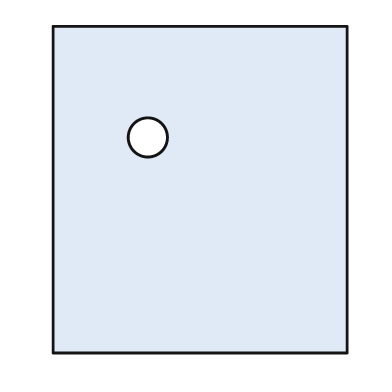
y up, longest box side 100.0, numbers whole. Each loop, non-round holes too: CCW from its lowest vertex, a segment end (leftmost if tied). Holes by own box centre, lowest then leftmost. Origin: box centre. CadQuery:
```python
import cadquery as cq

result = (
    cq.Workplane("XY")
    .moveTo(-45.0, -50.0)
    .lineTo(45.0, -50.0)
    .lineTo(45.0, 50.0)
    .lineTo(-45.0, 50.0)
    .close()
    .moveTo(-16.0, 16.0)
    .circle(6.0)
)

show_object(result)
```